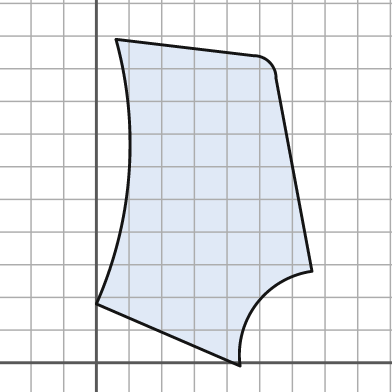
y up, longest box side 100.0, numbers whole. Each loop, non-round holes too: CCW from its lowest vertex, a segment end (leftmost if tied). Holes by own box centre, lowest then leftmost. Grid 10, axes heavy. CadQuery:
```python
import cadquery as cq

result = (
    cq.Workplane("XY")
    .moveTo(44.0, -1.0)
    .threePointArc((49.0, 18.0), (66.0, 28.0))
    .lineTo(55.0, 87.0)
    .threePointArc((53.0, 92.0), (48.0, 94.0))
    .lineTo(6.0, 99.0)
    .threePointArc((10.0, 58.0), (0.0, 18.0))
    .close()
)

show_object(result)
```